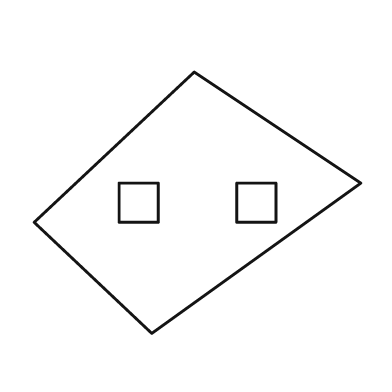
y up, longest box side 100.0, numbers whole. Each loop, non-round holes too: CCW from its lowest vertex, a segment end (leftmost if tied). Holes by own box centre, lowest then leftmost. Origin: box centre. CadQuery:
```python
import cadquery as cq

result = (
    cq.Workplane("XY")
    .moveTo(-14.0, -40.0)
    .lineTo(50.0, 6.0)
    .lineTo(-1.0, 40.0)
    .lineTo(-50.0, -6.0)
    .close()
    .moveTo(-24.0, -6.0)
    .lineTo(-12.0, -6.0)
    .lineTo(-12.0, 6.0)
    .lineTo(-24.0, 6.0)
    .close()
    .moveTo(12.0, -6.0)
    .lineTo(24.0, -6.0)
    .lineTo(24.0, 6.0)
    .lineTo(12.0, 6.0)
    .close()
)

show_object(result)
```